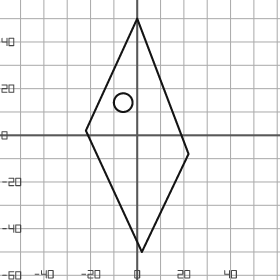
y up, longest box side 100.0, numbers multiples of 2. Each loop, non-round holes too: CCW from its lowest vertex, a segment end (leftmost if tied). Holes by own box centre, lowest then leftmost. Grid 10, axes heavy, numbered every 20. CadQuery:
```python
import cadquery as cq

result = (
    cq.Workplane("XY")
    .moveTo(2.0, -50.0)
    .lineTo(22.0, -8.0)
    .lineTo(0.0, 50.0)
    .lineTo(-22.0, 2.0)
    .close()
    .moveTo(-6.0, 14.0)
    .circle(4.0)
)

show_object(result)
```